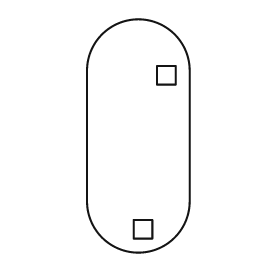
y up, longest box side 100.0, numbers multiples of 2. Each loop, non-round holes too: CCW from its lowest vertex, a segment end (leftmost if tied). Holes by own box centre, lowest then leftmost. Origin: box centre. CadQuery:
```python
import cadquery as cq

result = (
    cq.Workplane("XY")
    .moveTo(-22.0, -28.0)
    .threePointArc((0.0, -50.0), (22.0, -28.0))
    .lineTo(22.0, 28.0)
    .threePointArc((0.0, 50.0), (-22.0, 28.0))
    .close()
    .moveTo(-2.0, -44.0)
    .lineTo(6.0, -44.0)
    .lineTo(6.0, -36.0)
    .lineTo(-2.0, -36.0)
    .close()
    .moveTo(8.0, 22.0)
    .lineTo(16.0, 22.0)
    .lineTo(16.0, 30.0)
    .lineTo(8.0, 30.0)
    .close()
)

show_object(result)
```